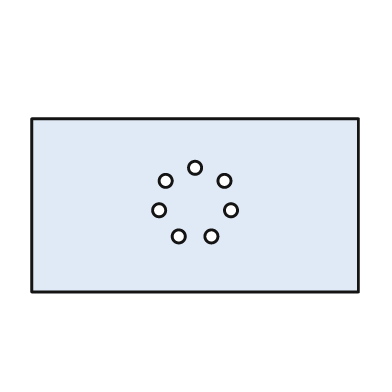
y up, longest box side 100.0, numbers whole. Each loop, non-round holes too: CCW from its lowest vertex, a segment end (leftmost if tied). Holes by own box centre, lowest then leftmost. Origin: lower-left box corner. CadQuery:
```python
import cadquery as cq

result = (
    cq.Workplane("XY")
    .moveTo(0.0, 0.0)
    .lineTo(100.0, 0.0)
    .lineTo(100.0, 53.0)
    .lineTo(0.0, 53.0)
    .close()
    .moveTo(45.0, 17.0)
    .circle(2.0)
    .moveTo(55.0, 17.0)
    .circle(2.0)
    .moveTo(39.0, 25.0)
    .circle(2.0)
    .moveTo(61.0, 25.0)
    .circle(2.0)
    .moveTo(41.0, 34.0)
    .circle(2.0)
    .moveTo(59.0, 34.0)
    .circle(2.0)
    .moveTo(50.0, 38.0)
    .circle(2.0)
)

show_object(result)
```